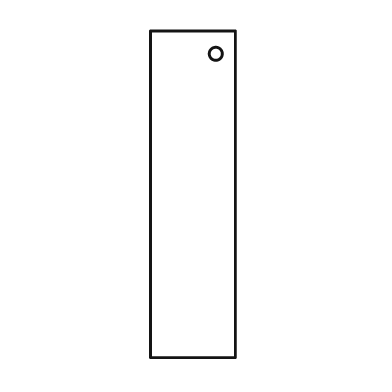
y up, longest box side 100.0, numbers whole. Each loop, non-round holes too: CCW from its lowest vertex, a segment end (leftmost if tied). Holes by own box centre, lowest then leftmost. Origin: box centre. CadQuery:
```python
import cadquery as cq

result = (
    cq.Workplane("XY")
    .moveTo(-13.0, -50.0)
    .lineTo(13.0, -50.0)
    .lineTo(13.0, 50.0)
    .lineTo(-13.0, 50.0)
    .close()
    .moveTo(7.0, 43.0)
    .circle(2.0)
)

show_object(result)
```